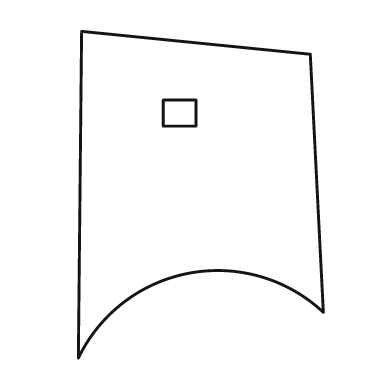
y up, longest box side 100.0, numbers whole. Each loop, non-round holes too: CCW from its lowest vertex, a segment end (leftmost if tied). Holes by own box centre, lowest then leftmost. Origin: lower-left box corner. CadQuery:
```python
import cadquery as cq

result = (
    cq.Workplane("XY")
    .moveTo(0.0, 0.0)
    .threePointArc((34.0, 26.0), (75.0, 14.0))
    .lineTo(71.0, 93.0)
    .lineTo(1.0, 100.0)
    .close()
    .moveTo(26.0, 71.0)
    .lineTo(36.0, 71.0)
    .lineTo(36.0, 79.0)
    .lineTo(26.0, 79.0)
    .close()
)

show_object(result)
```